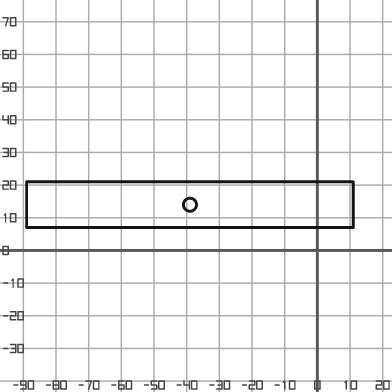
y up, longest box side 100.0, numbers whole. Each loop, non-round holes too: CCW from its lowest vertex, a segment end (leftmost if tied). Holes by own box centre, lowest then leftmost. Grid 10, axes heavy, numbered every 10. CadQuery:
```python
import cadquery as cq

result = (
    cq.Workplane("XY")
    .moveTo(-89.0, 7.0)
    .lineTo(11.0, 7.0)
    .lineTo(11.0, 21.0)
    .lineTo(-89.0, 21.0)
    .close()
    .moveTo(-39.0, 14.0)
    .circle(2.0)
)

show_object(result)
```